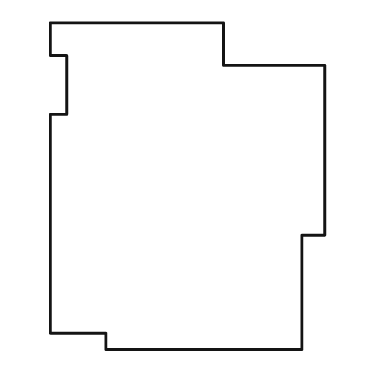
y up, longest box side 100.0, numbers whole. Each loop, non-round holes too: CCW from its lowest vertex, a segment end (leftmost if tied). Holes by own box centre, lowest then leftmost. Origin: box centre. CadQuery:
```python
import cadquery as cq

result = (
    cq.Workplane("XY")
    .moveTo(-25.0, -50.0)
    .lineTo(35.0, -50.0)
    .lineTo(35.0, -15.0)
    .lineTo(42.0, -15.0)
    .lineTo(42.0, 37.0)
    .lineTo(11.0, 37.0)
    .lineTo(11.0, 50.0)
    .lineTo(-42.0, 50.0)
    .lineTo(-42.0, 40.0)
    .lineTo(-37.0, 40.0)
    .lineTo(-37.0, 22.0)
    .lineTo(-42.0, 22.0)
    .lineTo(-42.0, -45.0)
    .lineTo(-25.0, -45.0)
    .close()
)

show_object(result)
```